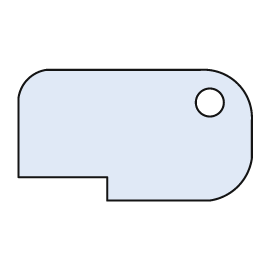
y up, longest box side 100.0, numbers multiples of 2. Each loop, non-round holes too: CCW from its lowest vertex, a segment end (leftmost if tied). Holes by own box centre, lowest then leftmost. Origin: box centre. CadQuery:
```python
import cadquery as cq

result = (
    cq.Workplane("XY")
    .moveTo(-12.0, -28.0)
    .lineTo(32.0, -28.0)
    .threePointArc((44.0, -22.0), (50.0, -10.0))
    .lineTo(50.0, 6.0)
    .threePointArc((44.0, 22.0), (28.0, 28.0))
    .lineTo(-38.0, 28.0)
    .threePointArc((-46.0, 24.0), (-50.0, 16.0))
    .lineTo(-50.0, -18.0)
    .lineTo(-12.0, -18.0)
    .close()
    .moveTo(32.0, 14.0)
    .circle(6.0)
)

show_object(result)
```